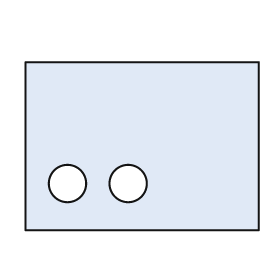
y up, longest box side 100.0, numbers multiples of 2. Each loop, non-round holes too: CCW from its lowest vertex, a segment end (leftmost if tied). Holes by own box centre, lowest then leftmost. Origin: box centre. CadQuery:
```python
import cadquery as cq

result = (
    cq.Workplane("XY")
    .moveTo(-50.0, -36.0)
    .lineTo(50.0, -36.0)
    .lineTo(50.0, 36.0)
    .lineTo(-50.0, 36.0)
    .close()
    .moveTo(-32.0, -16.0)
    .circle(8.0)
    .moveTo(-6.0, -16.0)
    .circle(8.0)
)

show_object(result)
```